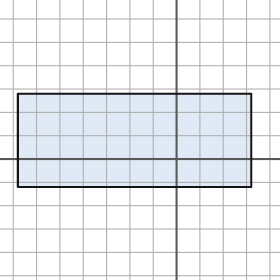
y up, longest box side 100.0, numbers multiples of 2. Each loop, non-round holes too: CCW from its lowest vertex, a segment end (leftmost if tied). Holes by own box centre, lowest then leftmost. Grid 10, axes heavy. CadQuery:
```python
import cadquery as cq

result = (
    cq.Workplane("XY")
    .moveTo(-68.0, -12.0)
    .lineTo(32.0, -12.0)
    .lineTo(32.0, 28.0)
    .lineTo(-68.0, 28.0)
    .close()
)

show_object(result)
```